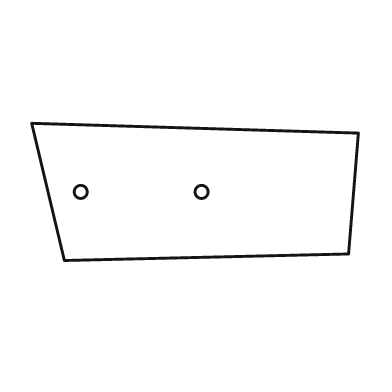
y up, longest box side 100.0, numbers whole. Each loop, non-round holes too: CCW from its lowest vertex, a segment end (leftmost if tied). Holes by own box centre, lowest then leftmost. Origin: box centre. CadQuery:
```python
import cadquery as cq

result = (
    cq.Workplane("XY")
    .moveTo(-40.0, -21.0)
    .lineTo(47.0, -19.0)
    .lineTo(50.0, 18.0)
    .lineTo(-50.0, 21.0)
    .close()
    .moveTo(-35.0, 0.0)
    .circle(2.0)
    .moveTo(2.0, 0.0)
    .circle(2.0)
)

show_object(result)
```